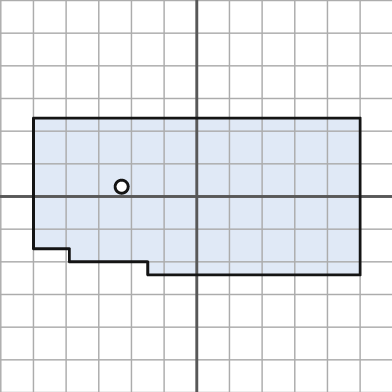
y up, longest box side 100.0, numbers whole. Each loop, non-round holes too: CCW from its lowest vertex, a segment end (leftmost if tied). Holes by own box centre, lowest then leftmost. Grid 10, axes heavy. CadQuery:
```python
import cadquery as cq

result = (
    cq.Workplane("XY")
    .moveTo(-15.0, -24.0)
    .lineTo(50.0, -24.0)
    .lineTo(50.0, 24.0)
    .lineTo(-50.0, 24.0)
    .lineTo(-50.0, -16.0)
    .lineTo(-39.0, -16.0)
    .lineTo(-39.0, -20.0)
    .lineTo(-15.0, -20.0)
    .close()
    .moveTo(-23.0, 3.0)
    .circle(2.0)
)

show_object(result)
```